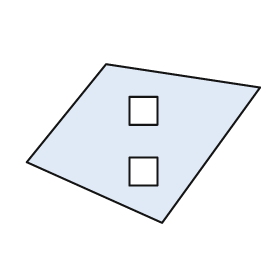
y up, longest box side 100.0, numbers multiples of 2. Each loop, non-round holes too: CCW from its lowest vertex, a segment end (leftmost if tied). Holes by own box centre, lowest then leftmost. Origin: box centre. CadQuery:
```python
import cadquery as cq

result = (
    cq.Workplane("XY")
    .moveTo(8.0, -34.0)
    .lineTo(50.0, 24.0)
    .lineTo(-16.0, 34.0)
    .lineTo(-50.0, -8.0)
    .close()
    .moveTo(-6.0, -18.0)
    .lineTo(6.0, -18.0)
    .lineTo(6.0, -6.0)
    .lineTo(-6.0, -6.0)
    .close()
    .moveTo(-6.0, 8.0)
    .lineTo(6.0, 8.0)
    .lineTo(6.0, 20.0)
    .lineTo(-6.0, 20.0)
    .close()
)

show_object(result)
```